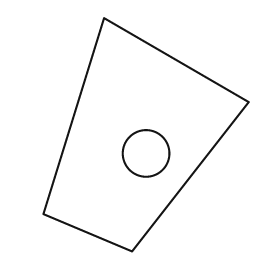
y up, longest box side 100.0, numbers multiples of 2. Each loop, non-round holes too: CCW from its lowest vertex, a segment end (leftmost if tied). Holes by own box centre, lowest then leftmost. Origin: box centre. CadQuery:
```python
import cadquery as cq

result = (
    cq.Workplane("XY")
    .moveTo(-6.0, -50.0)
    .lineTo(44.0, 14.0)
    .lineTo(-18.0, 50.0)
    .lineTo(-44.0, -34.0)
    .close()
    .moveTo(0.0, -8.0)
    .circle(10.0)
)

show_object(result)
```